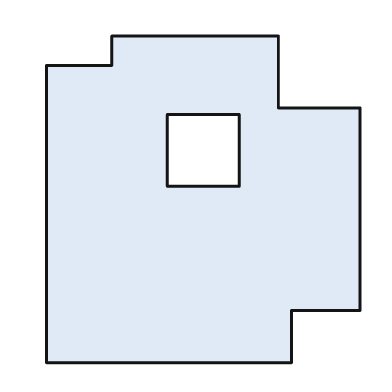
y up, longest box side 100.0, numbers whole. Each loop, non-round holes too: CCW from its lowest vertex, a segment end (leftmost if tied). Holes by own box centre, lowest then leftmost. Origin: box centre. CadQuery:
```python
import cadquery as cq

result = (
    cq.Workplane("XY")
    .moveTo(-48.0, -50.0)
    .lineTo(27.0, -50.0)
    .lineTo(27.0, -34.0)
    .lineTo(48.0, -34.0)
    .lineTo(48.0, 28.0)
    .lineTo(23.0, 28.0)
    .lineTo(23.0, 50.0)
    .lineTo(-28.0, 50.0)
    .lineTo(-28.0, 41.0)
    .lineTo(-48.0, 41.0)
    .close()
    .moveTo(-11.0, 4.0)
    .lineTo(11.0, 4.0)
    .lineTo(11.0, 26.0)
    .lineTo(-11.0, 26.0)
    .close()
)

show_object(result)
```